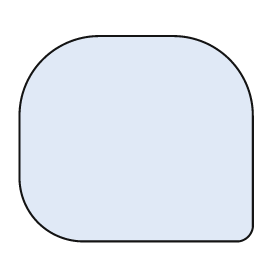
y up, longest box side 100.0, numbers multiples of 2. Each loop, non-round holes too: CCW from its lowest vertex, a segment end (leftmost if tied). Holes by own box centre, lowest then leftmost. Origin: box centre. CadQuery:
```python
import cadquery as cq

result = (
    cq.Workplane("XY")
    .moveTo(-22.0, -44.0)
    .lineTo(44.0, -44.0)
    .threePointArc((48.0, -42.0), (50.0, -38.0))
    .lineTo(50.0, 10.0)
    .threePointArc((40.0, 34.0), (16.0, 44.0))
    .lineTo(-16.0, 44.0)
    .threePointArc((-40.0, 34.0), (-50.0, 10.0))
    .lineTo(-50.0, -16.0)
    .threePointArc((-42.0, -36.0), (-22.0, -44.0))
    .close()
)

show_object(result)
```